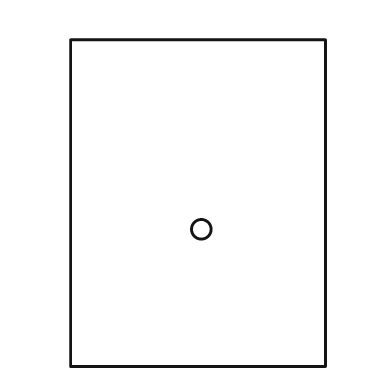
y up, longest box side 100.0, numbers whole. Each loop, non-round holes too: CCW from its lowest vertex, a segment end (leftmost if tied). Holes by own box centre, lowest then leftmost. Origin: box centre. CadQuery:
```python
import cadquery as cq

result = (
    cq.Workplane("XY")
    .moveTo(-39.0, -50.0)
    .lineTo(39.0, -50.0)
    .lineTo(39.0, 50.0)
    .lineTo(-39.0, 50.0)
    .close()
    .moveTo(1.0, -8.0)
    .circle(3.0)
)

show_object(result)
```